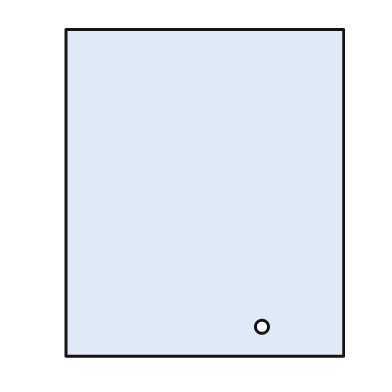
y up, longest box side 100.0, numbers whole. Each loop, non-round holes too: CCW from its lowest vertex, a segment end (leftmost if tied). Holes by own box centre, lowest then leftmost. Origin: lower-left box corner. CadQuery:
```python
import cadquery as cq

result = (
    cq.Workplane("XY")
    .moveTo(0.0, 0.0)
    .lineTo(85.0, 0.0)
    .lineTo(85.0, 100.0)
    .lineTo(0.0, 100.0)
    .close()
    .moveTo(60.0, 9.0)
    .circle(2.0)
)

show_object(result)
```